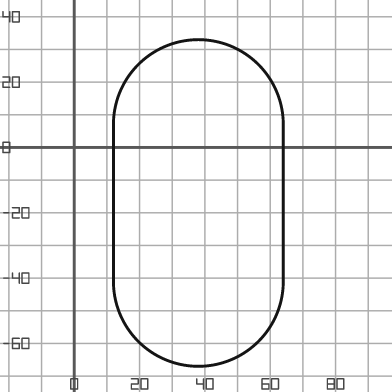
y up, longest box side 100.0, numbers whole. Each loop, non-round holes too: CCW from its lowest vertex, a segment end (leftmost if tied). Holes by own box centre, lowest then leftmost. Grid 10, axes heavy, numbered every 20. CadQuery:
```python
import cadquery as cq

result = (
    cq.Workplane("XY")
    .moveTo(12.0, -41.0)
    .threePointArc((38.0, -67.0), (64.0, -41.0))
    .lineTo(64.0, 7.0)
    .threePointArc((38.0, 33.0), (12.0, 7.0))
    .close()
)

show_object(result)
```